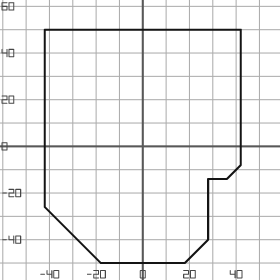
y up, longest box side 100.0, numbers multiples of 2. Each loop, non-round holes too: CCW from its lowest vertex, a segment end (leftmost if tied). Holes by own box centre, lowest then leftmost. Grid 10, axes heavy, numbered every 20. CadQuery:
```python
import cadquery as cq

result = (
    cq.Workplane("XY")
    .moveTo(-18.0, -50.0)
    .lineTo(18.0, -50.0)
    .lineTo(28.0, -40.0)
    .lineTo(28.0, -14.0)
    .lineTo(36.0, -14.0)
    .lineTo(42.0, -8.0)
    .lineTo(42.0, 50.0)
    .lineTo(-42.0, 50.0)
    .lineTo(-42.0, -26.0)
    .close()
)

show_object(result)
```